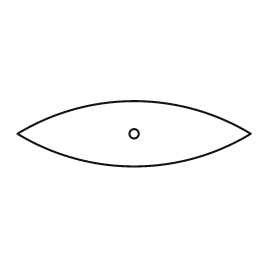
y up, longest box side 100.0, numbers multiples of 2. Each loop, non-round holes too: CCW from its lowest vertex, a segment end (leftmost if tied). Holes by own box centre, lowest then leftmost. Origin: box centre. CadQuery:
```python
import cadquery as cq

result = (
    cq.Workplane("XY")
    .moveTo(-50.0, 0.0)
    .threePointArc((0.0, -14.0), (50.0, 0.0))
    .threePointArc((0.0, 14.0), (-50.0, 0.0))
    .close()
    .moveTo(0.0, 0.0)
    .circle(2.0)
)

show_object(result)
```